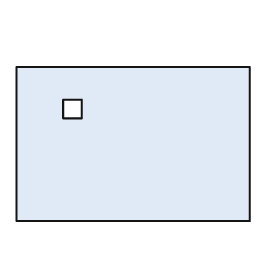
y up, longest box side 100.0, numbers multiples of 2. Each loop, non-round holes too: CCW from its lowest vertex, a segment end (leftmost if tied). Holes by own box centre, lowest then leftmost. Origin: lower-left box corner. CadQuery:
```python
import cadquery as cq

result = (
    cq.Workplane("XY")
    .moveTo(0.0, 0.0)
    .lineTo(100.0, 0.0)
    .lineTo(100.0, 66.0)
    .lineTo(0.0, 66.0)
    .close()
    .moveTo(20.0, 44.0)
    .lineTo(28.0, 44.0)
    .lineTo(28.0, 52.0)
    .lineTo(20.0, 52.0)
    .close()
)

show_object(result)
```